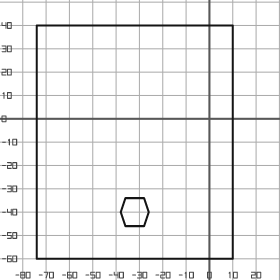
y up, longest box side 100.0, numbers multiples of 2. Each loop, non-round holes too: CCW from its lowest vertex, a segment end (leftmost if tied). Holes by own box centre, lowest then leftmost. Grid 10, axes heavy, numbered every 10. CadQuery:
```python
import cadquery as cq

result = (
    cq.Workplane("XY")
    .moveTo(-74.0, -60.0)
    .lineTo(10.0, -60.0)
    .lineTo(10.0, 40.0)
    .lineTo(-74.0, 40.0)
    .close()
    .moveTo(-36.0, -46.0)
    .lineTo(-28.0, -46.0)
    .lineTo(-26.0, -40.0)
    .lineTo(-28.0, -34.0)
    .lineTo(-36.0, -34.0)
    .lineTo(-38.0, -40.0)
    .close()
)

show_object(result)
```